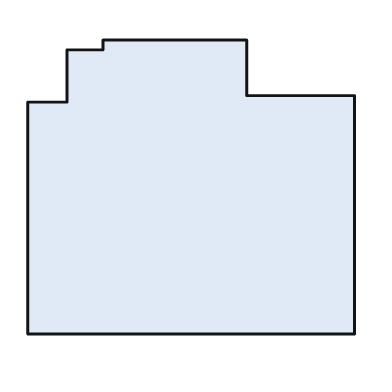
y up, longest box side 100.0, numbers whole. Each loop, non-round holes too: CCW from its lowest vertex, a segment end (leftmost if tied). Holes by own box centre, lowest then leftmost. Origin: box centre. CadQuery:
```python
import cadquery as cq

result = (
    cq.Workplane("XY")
    .moveTo(-50.0, -45.0)
    .lineTo(50.0, -45.0)
    .lineTo(50.0, 28.0)
    .lineTo(17.0, 28.0)
    .lineTo(17.0, 45.0)
    .lineTo(-27.0, 45.0)
    .lineTo(-27.0, 42.0)
    .lineTo(-38.0, 42.0)
    .lineTo(-38.0, 26.0)
    .lineTo(-50.0, 26.0)
    .close()
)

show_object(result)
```